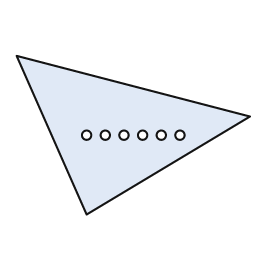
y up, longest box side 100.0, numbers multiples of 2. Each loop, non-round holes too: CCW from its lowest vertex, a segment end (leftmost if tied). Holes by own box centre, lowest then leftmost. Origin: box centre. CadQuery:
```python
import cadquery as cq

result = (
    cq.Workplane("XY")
    .moveTo(-20.0, -34.0)
    .lineTo(50.0, 8.0)
    .lineTo(-50.0, 34.0)
    .close()
    .moveTo(-20.0, 0.0)
    .circle(2.0)
    .moveTo(-12.0, 0.0)
    .circle(2.0)
    .moveTo(-4.0, 0.0)
    .circle(2.0)
    .moveTo(4.0, 0.0)
    .circle(2.0)
    .moveTo(12.0, 0.0)
    .circle(2.0)
    .moveTo(20.0, 0.0)
    .circle(2.0)
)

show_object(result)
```